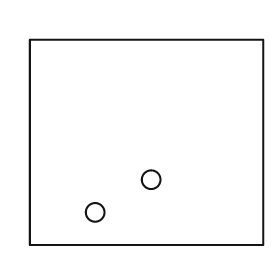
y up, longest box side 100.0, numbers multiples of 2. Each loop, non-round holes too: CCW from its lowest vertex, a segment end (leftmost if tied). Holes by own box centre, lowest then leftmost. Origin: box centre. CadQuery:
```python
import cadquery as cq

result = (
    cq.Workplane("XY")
    .moveTo(-50.0, -44.0)
    .lineTo(50.0, -44.0)
    .lineTo(50.0, 44.0)
    .lineTo(-50.0, 44.0)
    .close()
    .moveTo(-22.0, -30.0)
    .circle(4.0)
    .moveTo(2.0, -16.0)
    .circle(4.0)
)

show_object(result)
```